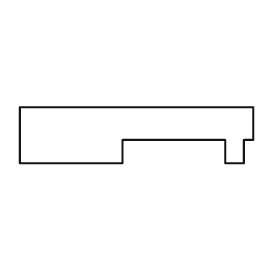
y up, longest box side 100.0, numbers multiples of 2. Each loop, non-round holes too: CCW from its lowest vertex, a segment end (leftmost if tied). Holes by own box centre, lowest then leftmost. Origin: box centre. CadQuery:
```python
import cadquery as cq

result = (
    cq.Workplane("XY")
    .moveTo(-50.0, -12.0)
    .lineTo(-6.0, -12.0)
    .lineTo(-6.0, -2.0)
    .lineTo(38.0, -2.0)
    .lineTo(38.0, -12.0)
    .lineTo(46.0, -12.0)
    .lineTo(46.0, -2.0)
    .lineTo(50.0, -2.0)
    .lineTo(50.0, 12.0)
    .lineTo(-50.0, 12.0)
    .close()
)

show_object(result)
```